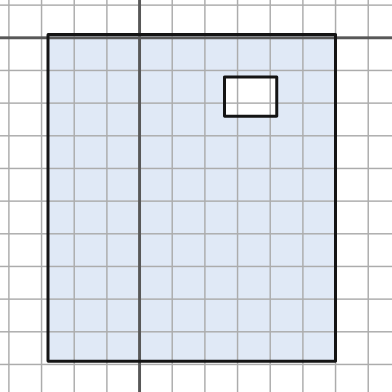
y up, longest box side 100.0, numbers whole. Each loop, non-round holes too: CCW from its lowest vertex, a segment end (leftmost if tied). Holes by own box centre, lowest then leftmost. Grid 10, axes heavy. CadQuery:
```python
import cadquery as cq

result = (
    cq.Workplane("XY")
    .moveTo(-28.0, -99.0)
    .lineTo(60.0, -99.0)
    .lineTo(60.0, 1.0)
    .lineTo(-28.0, 1.0)
    .close()
    .moveTo(26.0, -24.0)
    .lineTo(42.0, -24.0)
    .lineTo(42.0, -12.0)
    .lineTo(26.0, -12.0)
    .close()
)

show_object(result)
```